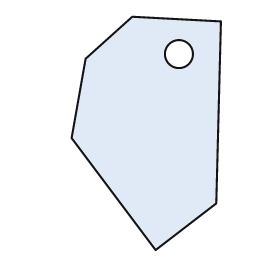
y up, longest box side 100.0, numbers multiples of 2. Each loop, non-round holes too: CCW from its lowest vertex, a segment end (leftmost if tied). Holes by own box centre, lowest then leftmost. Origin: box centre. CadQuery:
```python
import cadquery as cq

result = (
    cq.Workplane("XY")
    .moveTo(4.0, -50.0)
    .lineTo(30.0, -30.0)
    .lineTo(32.0, 48.0)
    .lineTo(-6.0, 50.0)
    .lineTo(-26.0, 32.0)
    .lineTo(-32.0, -2.0)
    .close()
    .moveTo(14.0, 34.0)
    .circle(6.0)
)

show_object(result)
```